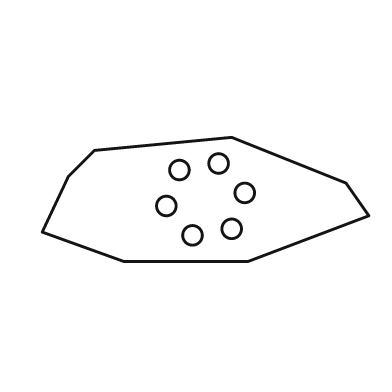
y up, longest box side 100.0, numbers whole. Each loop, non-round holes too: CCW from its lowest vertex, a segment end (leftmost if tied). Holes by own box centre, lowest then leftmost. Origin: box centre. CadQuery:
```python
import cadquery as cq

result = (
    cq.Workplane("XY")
    .moveTo(-25.0, -19.0)
    .lineTo(13.0, -19.0)
    .lineTo(50.0, -5.0)
    .lineTo(43.0, 5.0)
    .lineTo(8.0, 19.0)
    .lineTo(-34.0, 15.0)
    .lineTo(-42.0, 7.0)
    .lineTo(-50.0, -10.0)
    .close()
    .moveTo(-4.0, -11.0)
    .circle(3.0)
    .moveTo(8.0, -9.0)
    .circle(3.0)
    .moveTo(-12.0, -2.0)
    .circle(3.0)
    .moveTo(12.0, 2.0)
    .circle(3.0)
    .moveTo(-8.0, 9.0)
    .circle(3.0)
    .moveTo(4.0, 11.0)
    .circle(3.0)
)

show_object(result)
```